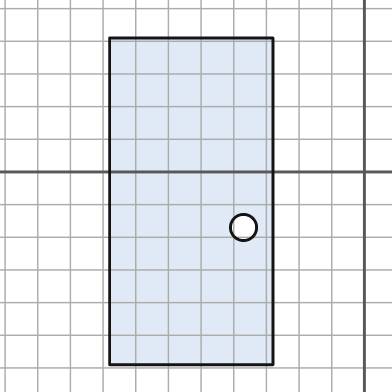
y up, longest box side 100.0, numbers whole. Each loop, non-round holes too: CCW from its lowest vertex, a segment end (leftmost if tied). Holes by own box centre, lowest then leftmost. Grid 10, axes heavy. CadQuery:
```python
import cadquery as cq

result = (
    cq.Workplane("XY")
    .moveTo(-78.0, -59.0)
    .lineTo(-28.0, -59.0)
    .lineTo(-28.0, 41.0)
    .lineTo(-78.0, 41.0)
    .close()
    .moveTo(-37.0, -17.0)
    .circle(4.0)
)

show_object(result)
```